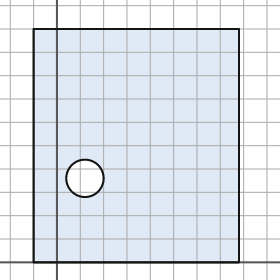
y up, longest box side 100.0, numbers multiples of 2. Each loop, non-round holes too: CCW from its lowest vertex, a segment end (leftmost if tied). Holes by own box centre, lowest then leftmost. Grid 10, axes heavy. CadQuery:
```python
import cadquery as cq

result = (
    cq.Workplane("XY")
    .moveTo(-10.0, 0.0)
    .lineTo(78.0, 0.0)
    .lineTo(78.0, 100.0)
    .lineTo(-10.0, 100.0)
    .close()
    .moveTo(12.0, 36.0)
    .circle(8.0)
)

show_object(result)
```